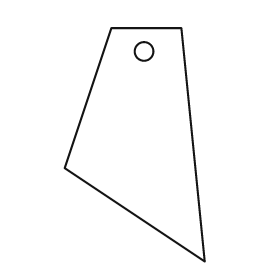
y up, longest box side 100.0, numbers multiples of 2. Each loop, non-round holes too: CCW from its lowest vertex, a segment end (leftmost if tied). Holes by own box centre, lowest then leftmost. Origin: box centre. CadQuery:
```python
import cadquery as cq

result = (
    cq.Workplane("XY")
    .moveTo(30.0, -50.0)
    .lineTo(20.0, 50.0)
    .lineTo(-10.0, 50.0)
    .lineTo(-30.0, -10.0)
    .close()
    .moveTo(4.0, 40.0)
    .circle(4.0)
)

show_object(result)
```